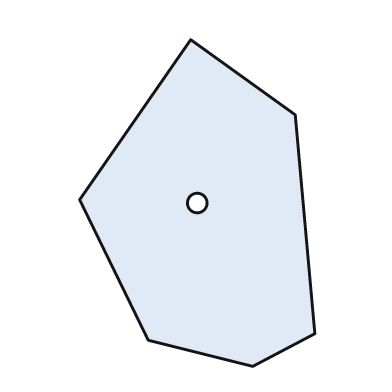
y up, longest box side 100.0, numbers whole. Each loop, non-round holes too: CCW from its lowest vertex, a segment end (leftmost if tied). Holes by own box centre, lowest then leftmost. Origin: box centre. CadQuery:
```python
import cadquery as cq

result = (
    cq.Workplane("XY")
    .moveTo(17.0, -50.0)
    .lineTo(36.0, -40.0)
    .lineTo(30.0, 27.0)
    .lineTo(-2.0, 50.0)
    .lineTo(-36.0, 1.0)
    .lineTo(-15.0, -42.0)
    .close()
    .moveTo(0.0, 0.0)
    .circle(3.0)
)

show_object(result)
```